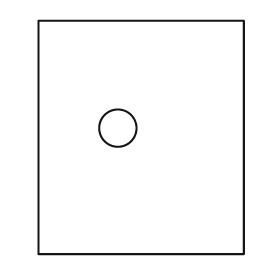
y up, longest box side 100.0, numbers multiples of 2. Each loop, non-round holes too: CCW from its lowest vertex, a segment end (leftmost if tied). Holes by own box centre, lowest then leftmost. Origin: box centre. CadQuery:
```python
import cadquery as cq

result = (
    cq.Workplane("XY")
    .moveTo(-44.0, -50.0)
    .lineTo(44.0, -50.0)
    .lineTo(44.0, 50.0)
    .lineTo(-44.0, 50.0)
    .close()
    .moveTo(-10.0, 4.0)
    .circle(8.0)
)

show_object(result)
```